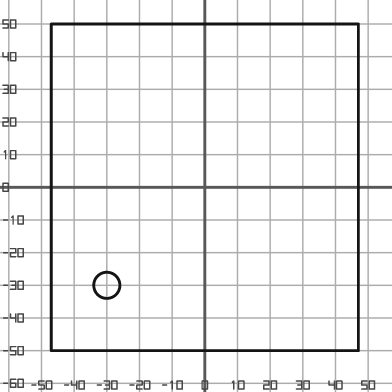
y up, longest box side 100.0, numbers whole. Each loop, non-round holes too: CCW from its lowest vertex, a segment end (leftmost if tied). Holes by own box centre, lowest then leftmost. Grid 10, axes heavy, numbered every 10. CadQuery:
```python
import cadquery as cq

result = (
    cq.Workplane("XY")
    .moveTo(-47.0, -50.0)
    .lineTo(47.0, -50.0)
    .lineTo(47.0, 50.0)
    .lineTo(-47.0, 50.0)
    .close()
    .moveTo(-30.0, -30.0)
    .circle(4.0)
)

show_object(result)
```